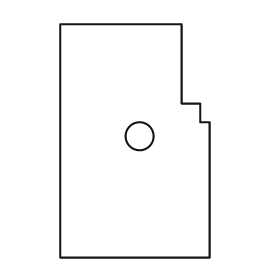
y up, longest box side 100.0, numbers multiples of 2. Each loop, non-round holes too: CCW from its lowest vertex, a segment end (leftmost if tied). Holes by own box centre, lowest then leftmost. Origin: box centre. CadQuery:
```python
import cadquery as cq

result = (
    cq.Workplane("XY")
    .moveTo(-32.0, -50.0)
    .lineTo(32.0, -50.0)
    .lineTo(32.0, 8.0)
    .lineTo(28.0, 8.0)
    .lineTo(28.0, 16.0)
    .lineTo(20.0, 16.0)
    .lineTo(20.0, 50.0)
    .lineTo(-32.0, 50.0)
    .close()
    .moveTo(2.0, 2.0)
    .circle(6.0)
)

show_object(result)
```